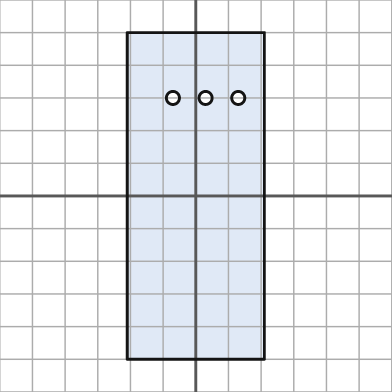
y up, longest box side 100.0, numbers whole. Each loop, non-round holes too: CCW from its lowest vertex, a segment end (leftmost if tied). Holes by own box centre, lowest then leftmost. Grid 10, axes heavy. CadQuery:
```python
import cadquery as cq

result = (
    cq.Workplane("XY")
    .moveTo(-21.0, -50.0)
    .lineTo(21.0, -50.0)
    .lineTo(21.0, 50.0)
    .lineTo(-21.0, 50.0)
    .close()
    .moveTo(-7.0, 30.0)
    .circle(2.0)
    .moveTo(3.0, 30.0)
    .circle(2.0)
    .moveTo(13.0, 30.0)
    .circle(2.0)
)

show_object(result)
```